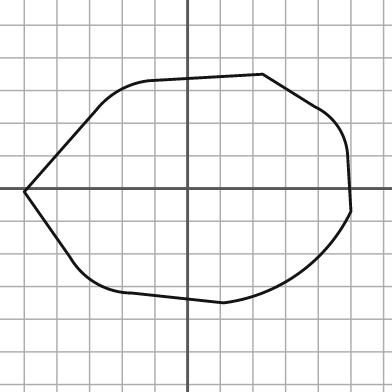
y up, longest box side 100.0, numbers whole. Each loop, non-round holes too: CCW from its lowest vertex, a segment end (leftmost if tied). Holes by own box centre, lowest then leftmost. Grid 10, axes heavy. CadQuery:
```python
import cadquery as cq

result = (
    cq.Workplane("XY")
    .moveTo(11.0, -35.0)
    .threePointArc((34.0, -26.0), (50.0, -7.0))
    .lineTo(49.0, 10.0)
    .threePointArc((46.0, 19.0), (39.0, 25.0))
    .lineTo(23.0, 35.0)
    .lineTo(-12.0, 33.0)
    .threePointArc((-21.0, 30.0), (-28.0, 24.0))
    .lineTo(-50.0, -1.0)
    .lineTo(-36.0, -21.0)
    .threePointArc((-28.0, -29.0), (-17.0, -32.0))
    .close()
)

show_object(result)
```